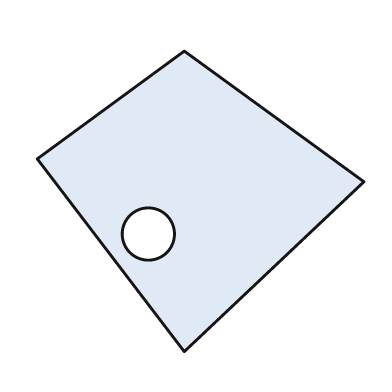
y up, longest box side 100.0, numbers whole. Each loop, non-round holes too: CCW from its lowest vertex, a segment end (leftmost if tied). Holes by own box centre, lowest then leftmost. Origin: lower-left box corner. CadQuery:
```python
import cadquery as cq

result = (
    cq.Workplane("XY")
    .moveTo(45.0, 0.0)
    .lineTo(100.0, 52.0)
    .lineTo(45.0, 92.0)
    .lineTo(0.0, 59.0)
    .close()
    .moveTo(34.0, 36.0)
    .circle(8.0)
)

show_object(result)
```